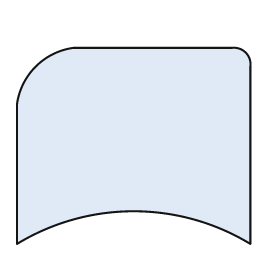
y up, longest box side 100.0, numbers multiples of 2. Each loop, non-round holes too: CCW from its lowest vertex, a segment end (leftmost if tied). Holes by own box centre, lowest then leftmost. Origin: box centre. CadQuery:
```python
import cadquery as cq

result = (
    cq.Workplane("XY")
    .moveTo(-50.0, -42.0)
    .threePointArc((0.0, -28.0), (50.0, -42.0))
    .lineTo(50.0, 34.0)
    .threePointArc((48.0, 40.0), (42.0, 42.0))
    .lineTo(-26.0, 42.0)
    .threePointArc((-42.0, 34.0), (-50.0, 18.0))
    .close()
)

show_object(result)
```